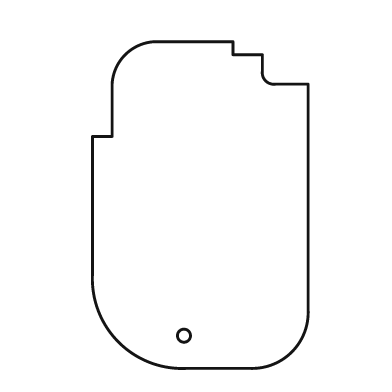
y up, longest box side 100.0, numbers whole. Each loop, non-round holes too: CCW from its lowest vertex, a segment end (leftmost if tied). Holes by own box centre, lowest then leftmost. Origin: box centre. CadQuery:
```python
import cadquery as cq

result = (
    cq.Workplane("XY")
    .moveTo(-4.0, -50.0)
    .lineTo(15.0, -50.0)
    .threePointArc((28.0, -45.0), (33.0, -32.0))
    .lineTo(33.0, 37.0)
    .lineTo(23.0, 37.0)
    .threePointArc((20.0, 38.0), (19.0, 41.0))
    .lineTo(19.0, 46.0)
    .lineTo(10.0, 46.0)
    .lineTo(10.0, 50.0)
    .lineTo(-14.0, 50.0)
    .threePointArc((-23.0, 46.0), (-27.0, 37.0))
    .lineTo(-27.0, 21.0)
    .lineTo(-33.0, 21.0)
    .lineTo(-33.0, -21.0)
    .threePointArc((-25.0, -42.0), (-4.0, -50.0))
    .close()
    .moveTo(-5.0, -40.0)
    .circle(2.0)
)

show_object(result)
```